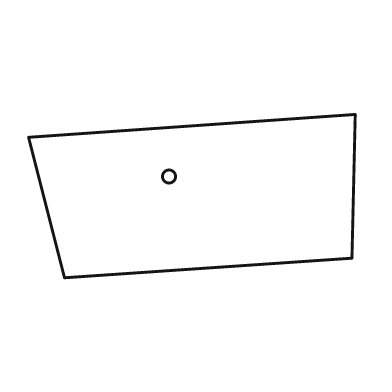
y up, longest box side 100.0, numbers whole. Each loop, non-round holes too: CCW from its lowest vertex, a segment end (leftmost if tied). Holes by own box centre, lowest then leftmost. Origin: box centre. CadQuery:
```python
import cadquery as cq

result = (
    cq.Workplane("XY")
    .moveTo(-39.0, -25.0)
    .lineTo(49.0, -19.0)
    .lineTo(50.0, 25.0)
    .lineTo(-50.0, 18.0)
    .close()
    .moveTo(-7.0, 6.0)
    .circle(2.0)
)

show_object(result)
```